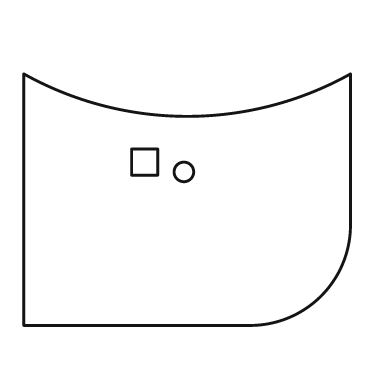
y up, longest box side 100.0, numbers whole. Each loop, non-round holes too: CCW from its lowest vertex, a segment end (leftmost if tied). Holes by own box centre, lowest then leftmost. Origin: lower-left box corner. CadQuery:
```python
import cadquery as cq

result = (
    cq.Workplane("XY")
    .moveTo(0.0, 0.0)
    .lineTo(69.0, 0.0)
    .threePointArc((91.0, 9.0), (100.0, 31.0))
    .lineTo(100.0, 77.0)
    .threePointArc((50.0, 64.0), (0.0, 77.0))
    .close()
    .moveTo(49.0, 47.0)
    .circle(3.0)
    .moveTo(33.0, 46.0)
    .lineTo(41.0, 46.0)
    .lineTo(41.0, 54.0)
    .lineTo(33.0, 54.0)
    .close()
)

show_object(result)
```